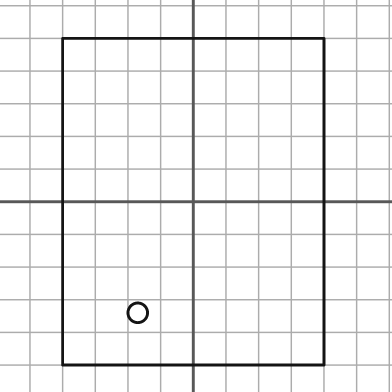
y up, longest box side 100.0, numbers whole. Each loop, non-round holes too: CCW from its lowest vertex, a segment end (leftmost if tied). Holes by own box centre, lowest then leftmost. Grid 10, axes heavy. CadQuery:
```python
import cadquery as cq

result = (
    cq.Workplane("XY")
    .moveTo(-40.0, -50.0)
    .lineTo(40.0, -50.0)
    .lineTo(40.0, 50.0)
    .lineTo(-40.0, 50.0)
    .close()
    .moveTo(-17.0, -34.0)
    .circle(3.0)
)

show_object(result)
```